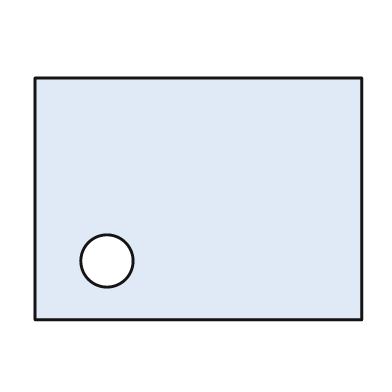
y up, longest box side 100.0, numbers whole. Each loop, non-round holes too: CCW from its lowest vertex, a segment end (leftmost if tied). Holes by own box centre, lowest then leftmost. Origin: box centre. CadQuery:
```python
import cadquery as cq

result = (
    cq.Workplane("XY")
    .moveTo(-50.0, -37.0)
    .lineTo(50.0, -37.0)
    .lineTo(50.0, 37.0)
    .lineTo(-50.0, 37.0)
    .close()
    .moveTo(-28.0, -19.0)
    .circle(8.0)
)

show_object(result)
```